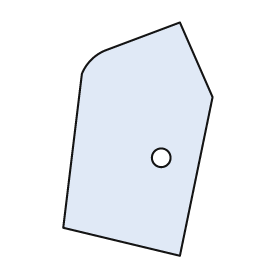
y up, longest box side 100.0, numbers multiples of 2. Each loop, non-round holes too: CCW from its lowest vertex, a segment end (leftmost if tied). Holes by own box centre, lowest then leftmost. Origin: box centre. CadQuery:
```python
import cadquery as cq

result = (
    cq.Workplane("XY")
    .moveTo(18.0, -50.0)
    .lineTo(32.0, 18.0)
    .lineTo(18.0, 50.0)
    .lineTo(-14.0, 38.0)
    .threePointArc((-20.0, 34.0), (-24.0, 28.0))
    .lineTo(-32.0, -38.0)
    .close()
    .moveTo(10.0, -8.0)
    .circle(4.0)
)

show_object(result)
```